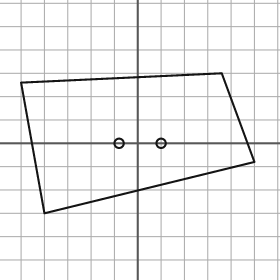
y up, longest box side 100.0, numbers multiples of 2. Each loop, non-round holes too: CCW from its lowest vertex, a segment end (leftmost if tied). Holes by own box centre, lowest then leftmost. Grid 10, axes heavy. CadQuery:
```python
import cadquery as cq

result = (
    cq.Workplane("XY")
    .moveTo(-40.0, -30.0)
    .lineTo(50.0, -8.0)
    .lineTo(36.0, 30.0)
    .lineTo(-50.0, 26.0)
    .close()
    .moveTo(-8.0, 0.0)
    .circle(2.0)
    .moveTo(10.0, 0.0)
    .circle(2.0)
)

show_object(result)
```